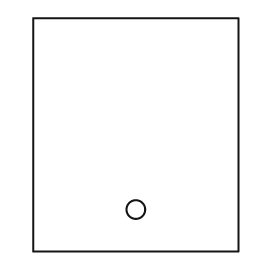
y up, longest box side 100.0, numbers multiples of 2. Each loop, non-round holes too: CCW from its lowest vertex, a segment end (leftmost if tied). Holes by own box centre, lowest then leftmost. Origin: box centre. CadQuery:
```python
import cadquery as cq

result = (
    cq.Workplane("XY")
    .moveTo(-44.0, -50.0)
    .lineTo(44.0, -50.0)
    .lineTo(44.0, 50.0)
    .lineTo(-44.0, 50.0)
    .close()
    .moveTo(0.0, -32.0)
    .circle(4.0)
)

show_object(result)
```